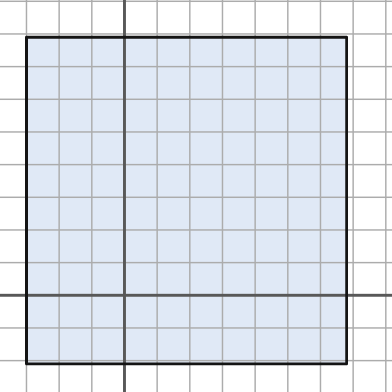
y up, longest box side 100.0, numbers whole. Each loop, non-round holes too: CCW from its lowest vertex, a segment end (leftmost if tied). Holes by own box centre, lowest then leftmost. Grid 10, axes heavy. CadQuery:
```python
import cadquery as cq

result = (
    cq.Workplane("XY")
    .moveTo(-30.0, -21.0)
    .lineTo(68.0, -21.0)
    .lineTo(68.0, 79.0)
    .lineTo(-30.0, 79.0)
    .close()
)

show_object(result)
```